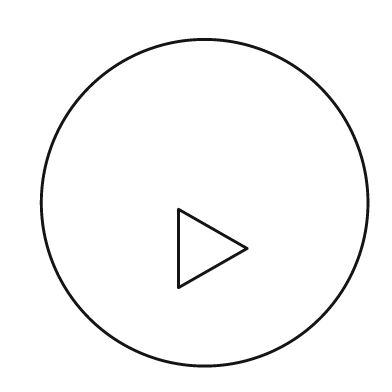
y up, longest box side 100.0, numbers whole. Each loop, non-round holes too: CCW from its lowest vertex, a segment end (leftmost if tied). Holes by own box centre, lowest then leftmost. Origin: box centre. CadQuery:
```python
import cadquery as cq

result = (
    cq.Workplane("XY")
    .moveTo(0.0, 0.0)
    .circle(50.0)
    .moveTo(-8.0, -26.0)
    .lineTo(13.0, -14.0)
    .lineTo(-8.0, -2.0)
    .close()
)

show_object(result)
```